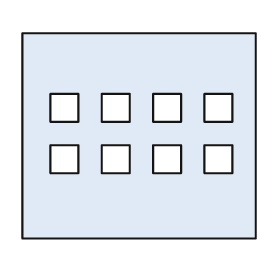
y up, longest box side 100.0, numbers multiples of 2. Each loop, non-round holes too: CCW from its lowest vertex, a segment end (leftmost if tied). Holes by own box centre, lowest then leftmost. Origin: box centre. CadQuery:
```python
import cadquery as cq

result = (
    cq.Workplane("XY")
    .moveTo(-50.0, -44.0)
    .lineTo(50.0, -44.0)
    .lineTo(50.0, 44.0)
    .lineTo(-50.0, 44.0)
    .close()
    .moveTo(-38.0, -16.0)
    .lineTo(-26.0, -16.0)
    .lineTo(-26.0, -4.0)
    .lineTo(-38.0, -4.0)
    .close()
    .moveTo(-16.0, -16.0)
    .lineTo(-4.0, -16.0)
    .lineTo(-4.0, -4.0)
    .lineTo(-16.0, -4.0)
    .close()
    .moveTo(6.0, -16.0)
    .lineTo(18.0, -16.0)
    .lineTo(18.0, -4.0)
    .lineTo(6.0, -4.0)
    .close()
    .moveTo(28.0, -16.0)
    .lineTo(40.0, -16.0)
    .lineTo(40.0, -4.0)
    .lineTo(28.0, -4.0)
    .close()
    .moveTo(-38.0, 6.0)
    .lineTo(-26.0, 6.0)
    .lineTo(-26.0, 18.0)
    .lineTo(-38.0, 18.0)
    .close()
    .moveTo(-16.0, 6.0)
    .lineTo(-4.0, 6.0)
    .lineTo(-4.0, 18.0)
    .lineTo(-16.0, 18.0)
    .close()
    .moveTo(6.0, 6.0)
    .lineTo(18.0, 6.0)
    .lineTo(18.0, 18.0)
    .lineTo(6.0, 18.0)
    .close()
    .moveTo(28.0, 6.0)
    .lineTo(40.0, 6.0)
    .lineTo(40.0, 18.0)
    .lineTo(28.0, 18.0)
    .close()
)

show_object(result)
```